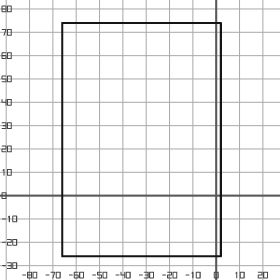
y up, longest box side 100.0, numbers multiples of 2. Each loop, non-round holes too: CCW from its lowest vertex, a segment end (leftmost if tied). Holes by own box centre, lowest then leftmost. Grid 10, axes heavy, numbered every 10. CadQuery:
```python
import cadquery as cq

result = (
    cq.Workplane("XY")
    .moveTo(-66.0, -26.0)
    .lineTo(2.0, -26.0)
    .lineTo(2.0, 74.0)
    .lineTo(-66.0, 74.0)
    .close()
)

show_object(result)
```